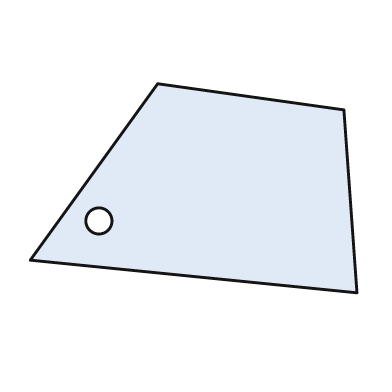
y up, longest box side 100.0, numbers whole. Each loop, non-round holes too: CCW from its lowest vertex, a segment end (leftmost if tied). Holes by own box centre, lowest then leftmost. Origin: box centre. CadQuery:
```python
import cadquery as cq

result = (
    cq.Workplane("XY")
    .moveTo(50.0, -32.0)
    .lineTo(46.0, 24.0)
    .lineTo(-11.0, 32.0)
    .lineTo(-50.0, -22.0)
    .close()
    .moveTo(-29.0, -10.0)
    .circle(4.0)
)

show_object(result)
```